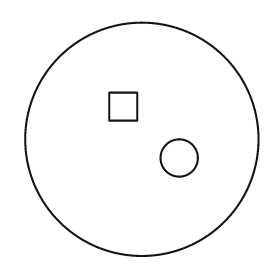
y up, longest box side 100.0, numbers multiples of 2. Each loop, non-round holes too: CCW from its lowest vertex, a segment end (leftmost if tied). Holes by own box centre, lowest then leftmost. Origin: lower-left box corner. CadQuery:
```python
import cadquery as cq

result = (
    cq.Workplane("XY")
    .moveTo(50.0, 50.0)
    .circle(50.0)
    .moveTo(66.0, 42.0)
    .circle(8.0)
    .moveTo(36.0, 58.0)
    .lineTo(48.0, 58.0)
    .lineTo(48.0, 70.0)
    .lineTo(36.0, 70.0)
    .close()
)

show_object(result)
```